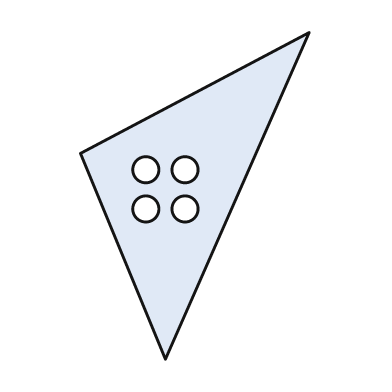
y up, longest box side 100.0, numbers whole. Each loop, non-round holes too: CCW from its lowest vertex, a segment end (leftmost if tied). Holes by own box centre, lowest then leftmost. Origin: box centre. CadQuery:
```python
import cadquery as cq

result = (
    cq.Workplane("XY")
    .moveTo(-9.0, -50.0)
    .lineTo(35.0, 50.0)
    .lineTo(-35.0, 13.0)
    .close()
    .moveTo(-15.0, -4.0)
    .circle(4.0)
    .moveTo(-3.0, -4.0)
    .circle(4.0)
    .moveTo(-15.0, 8.0)
    .circle(4.0)
    .moveTo(-3.0, 8.0)
    .circle(4.0)
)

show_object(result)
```